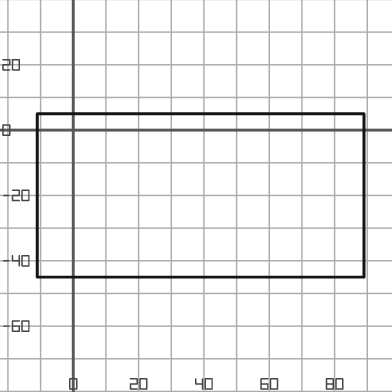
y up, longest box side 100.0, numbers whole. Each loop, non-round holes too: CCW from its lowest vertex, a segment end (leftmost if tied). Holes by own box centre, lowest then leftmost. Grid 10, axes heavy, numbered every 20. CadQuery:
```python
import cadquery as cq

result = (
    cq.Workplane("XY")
    .moveTo(-11.0, -45.0)
    .lineTo(89.0, -45.0)
    .lineTo(89.0, 5.0)
    .lineTo(-11.0, 5.0)
    .close()
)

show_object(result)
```